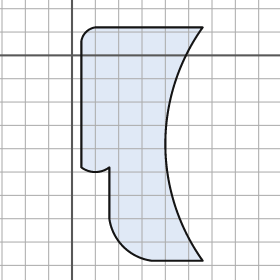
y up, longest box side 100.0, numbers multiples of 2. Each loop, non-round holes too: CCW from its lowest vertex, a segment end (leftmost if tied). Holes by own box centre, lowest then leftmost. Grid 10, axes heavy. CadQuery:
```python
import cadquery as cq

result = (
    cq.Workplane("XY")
    .moveTo(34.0, -88.0)
    .lineTo(56.0, -88.0)
    .threePointArc((40.0, -38.0), (56.0, 12.0))
    .lineTo(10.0, 12.0)
    .threePointArc((6.0, 10.0), (4.0, 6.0))
    .lineTo(4.0, -48.0)
    .threePointArc((10.0, -50.0), (16.0, -48.0))
    .lineTo(16.0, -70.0)
    .threePointArc((22.0, -82.0), (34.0, -88.0))
    .close()
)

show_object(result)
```